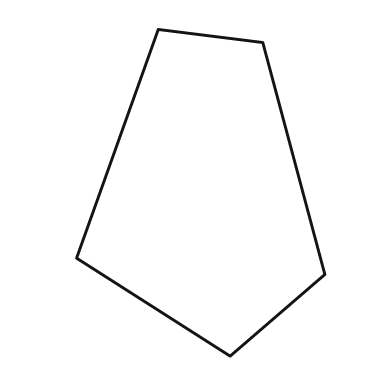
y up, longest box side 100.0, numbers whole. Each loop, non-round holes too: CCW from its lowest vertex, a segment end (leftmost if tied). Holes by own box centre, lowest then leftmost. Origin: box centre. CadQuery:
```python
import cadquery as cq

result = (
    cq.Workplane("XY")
    .moveTo(9.0, -50.0)
    .lineTo(38.0, -25.0)
    .lineTo(19.0, 46.0)
    .lineTo(-13.0, 50.0)
    .lineTo(-38.0, -20.0)
    .close()
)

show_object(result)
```